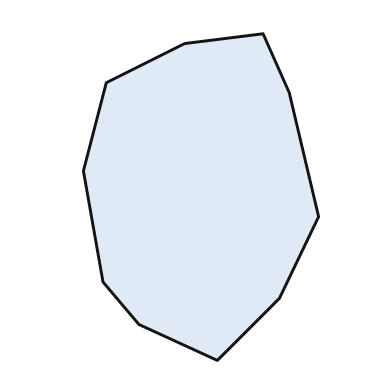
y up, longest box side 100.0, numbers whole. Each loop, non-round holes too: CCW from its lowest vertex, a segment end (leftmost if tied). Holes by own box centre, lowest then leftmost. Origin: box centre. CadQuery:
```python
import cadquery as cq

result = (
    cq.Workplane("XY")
    .moveTo(5.0, -50.0)
    .lineTo(24.0, -31.0)
    .lineTo(36.0, -6.0)
    .lineTo(27.0, 32.0)
    .lineTo(19.0, 50.0)
    .lineTo(-5.0, 47.0)
    .lineTo(-29.0, 35.0)
    .lineTo(-36.0, 8.0)
    .lineTo(-30.0, -26.0)
    .lineTo(-19.0, -39.0)
    .close()
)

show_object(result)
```